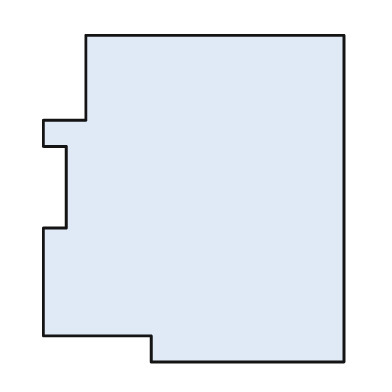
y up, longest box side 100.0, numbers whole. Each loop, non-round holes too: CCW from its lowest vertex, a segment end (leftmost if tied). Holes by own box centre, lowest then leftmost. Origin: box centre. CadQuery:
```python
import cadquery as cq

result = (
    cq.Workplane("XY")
    .moveTo(-13.0, -50.0)
    .lineTo(46.0, -50.0)
    .lineTo(46.0, 50.0)
    .lineTo(-33.0, 50.0)
    .lineTo(-33.0, 24.0)
    .lineTo(-46.0, 24.0)
    .lineTo(-46.0, 16.0)
    .lineTo(-39.0, 16.0)
    .lineTo(-39.0, -9.0)
    .lineTo(-46.0, -9.0)
    .lineTo(-46.0, -42.0)
    .lineTo(-13.0, -42.0)
    .close()
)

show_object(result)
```